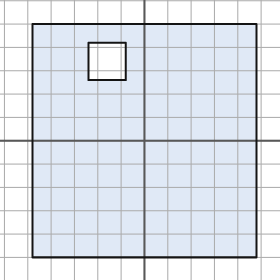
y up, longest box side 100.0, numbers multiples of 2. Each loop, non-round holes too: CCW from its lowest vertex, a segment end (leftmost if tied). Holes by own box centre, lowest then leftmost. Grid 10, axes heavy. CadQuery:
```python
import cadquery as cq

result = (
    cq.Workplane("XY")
    .moveTo(-48.0, -50.0)
    .lineTo(48.0, -50.0)
    .lineTo(48.0, 50.0)
    .lineTo(-48.0, 50.0)
    .close()
    .moveTo(-24.0, 26.0)
    .lineTo(-8.0, 26.0)
    .lineTo(-8.0, 42.0)
    .lineTo(-24.0, 42.0)
    .close()
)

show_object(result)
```